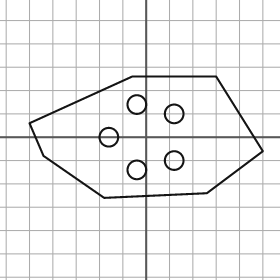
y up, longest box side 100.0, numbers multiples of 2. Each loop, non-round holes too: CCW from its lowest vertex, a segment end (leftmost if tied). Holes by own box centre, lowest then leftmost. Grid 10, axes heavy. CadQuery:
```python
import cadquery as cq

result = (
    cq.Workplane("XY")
    .moveTo(-18.0, -26.0)
    .lineTo(26.0, -24.0)
    .lineTo(50.0, -6.0)
    .lineTo(30.0, 26.0)
    .lineTo(-6.0, 26.0)
    .lineTo(-50.0, 6.0)
    .lineTo(-44.0, -8.0)
    .close()
    .moveTo(-4.0, -14.0)
    .circle(4.0)
    .moveTo(12.0, -10.0)
    .circle(4.0)
    .moveTo(-16.0, 0.0)
    .circle(4.0)
    .moveTo(12.0, 10.0)
    .circle(4.0)
    .moveTo(-4.0, 14.0)
    .circle(4.0)
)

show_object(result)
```